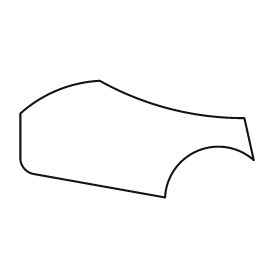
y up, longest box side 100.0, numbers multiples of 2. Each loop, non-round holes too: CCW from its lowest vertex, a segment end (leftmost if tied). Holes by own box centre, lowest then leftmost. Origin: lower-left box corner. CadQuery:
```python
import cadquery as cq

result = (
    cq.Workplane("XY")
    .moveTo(62.0, 0.0)
    .threePointArc((76.0, 20.0), (100.0, 16.0))
    .lineTo(96.0, 34.0)
    .threePointArc((64.0, 38.0), (34.0, 50.0))
    .threePointArc((16.0, 46.0), (0.0, 36.0))
    .lineTo(0.0, 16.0)
    .threePointArc((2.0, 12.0), (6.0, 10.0))
    .close()
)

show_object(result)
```